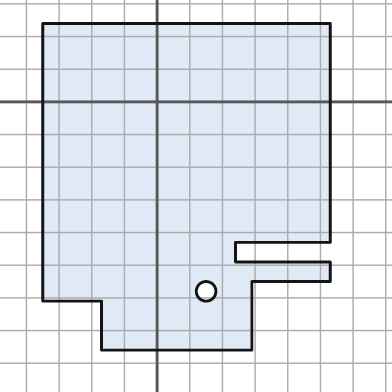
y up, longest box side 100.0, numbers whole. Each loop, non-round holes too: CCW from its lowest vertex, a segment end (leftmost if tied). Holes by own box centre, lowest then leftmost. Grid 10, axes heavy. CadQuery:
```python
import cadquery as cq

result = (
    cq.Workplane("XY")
    .moveTo(-17.0, -76.0)
    .lineTo(29.0, -76.0)
    .lineTo(29.0, -55.0)
    .lineTo(53.0, -55.0)
    .lineTo(53.0, -49.0)
    .lineTo(24.0, -49.0)
    .lineTo(24.0, -43.0)
    .lineTo(53.0, -43.0)
    .lineTo(53.0, 24.0)
    .lineTo(-35.0, 24.0)
    .lineTo(-35.0, -61.0)
    .lineTo(-17.0, -61.0)
    .close()
    .moveTo(15.0, -58.0)
    .circle(3.0)
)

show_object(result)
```